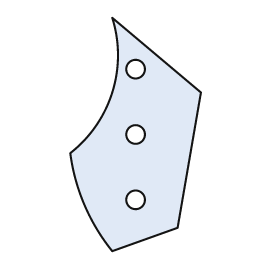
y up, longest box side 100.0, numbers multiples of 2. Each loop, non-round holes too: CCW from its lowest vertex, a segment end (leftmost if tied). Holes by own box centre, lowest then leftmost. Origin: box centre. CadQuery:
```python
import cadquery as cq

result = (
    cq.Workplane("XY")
    .moveTo(-10.0, -50.0)
    .lineTo(18.0, -40.0)
    .lineTo(28.0, 18.0)
    .lineTo(-10.0, 50.0)
    .threePointArc((-10.0, 18.0), (-28.0, -8.0))
    .threePointArc((-22.0, -30.0), (-10.0, -50.0))
    .close()
    .moveTo(0.0, -28.0)
    .circle(4.0)
    .moveTo(0.0, 0.0)
    .circle(4.0)
    .moveTo(0.0, 28.0)
    .circle(4.0)
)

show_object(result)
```